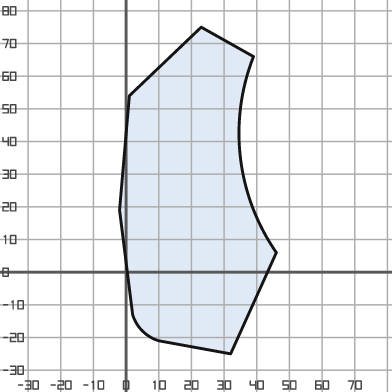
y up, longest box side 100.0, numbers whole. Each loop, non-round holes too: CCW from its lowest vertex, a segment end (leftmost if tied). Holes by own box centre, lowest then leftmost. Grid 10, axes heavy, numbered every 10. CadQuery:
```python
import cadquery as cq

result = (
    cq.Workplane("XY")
    .moveTo(32.0, -25.0)
    .lineTo(46.0, 6.0)
    .threePointArc((35.0, 35.0), (39.0, 66.0))
    .lineTo(23.0, 75.0)
    .lineTo(1.0, 54.0)
    .lineTo(-2.0, 19.0)
    .lineTo(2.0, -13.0)
    .threePointArc((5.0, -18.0), (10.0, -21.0))
    .close()
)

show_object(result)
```